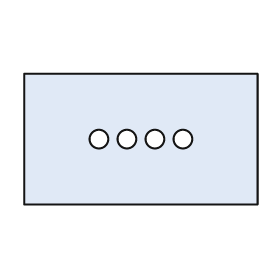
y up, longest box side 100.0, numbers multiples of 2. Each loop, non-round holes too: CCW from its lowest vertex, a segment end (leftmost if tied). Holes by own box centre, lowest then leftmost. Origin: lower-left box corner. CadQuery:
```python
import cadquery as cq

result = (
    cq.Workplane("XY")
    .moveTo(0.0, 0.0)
    .lineTo(100.0, 0.0)
    .lineTo(100.0, 56.0)
    .lineTo(0.0, 56.0)
    .close()
    .moveTo(32.0, 28.0)
    .circle(4.0)
    .moveTo(44.0, 28.0)
    .circle(4.0)
    .moveTo(56.0, 28.0)
    .circle(4.0)
    .moveTo(68.0, 28.0)
    .circle(4.0)
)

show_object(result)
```